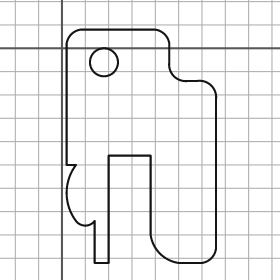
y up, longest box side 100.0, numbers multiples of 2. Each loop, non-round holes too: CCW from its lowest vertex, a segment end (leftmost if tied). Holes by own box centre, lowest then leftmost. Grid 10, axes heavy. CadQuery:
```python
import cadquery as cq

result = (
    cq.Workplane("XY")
    .moveTo(14.0, -92.0)
    .lineTo(20.0, -92.0)
    .lineTo(20.0, -46.0)
    .lineTo(38.0, -46.0)
    .lineTo(38.0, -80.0)
    .threePointArc((42.0, -88.0), (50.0, -92.0))
    .lineTo(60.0, -92.0)
    .threePointArc((64.0, -90.0), (66.0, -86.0))
    .lineTo(66.0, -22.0)
    .threePointArc((64.0, -16.0), (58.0, -14.0))
    .lineTo(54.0, -14.0)
    .threePointArc((48.0, -12.0), (46.0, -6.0))
    .lineTo(46.0, 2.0)
    .threePointArc((44.0, 6.0), (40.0, 8.0))
    .lineTo(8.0, 8.0)
    .threePointArc((4.0, 6.0), (2.0, 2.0))
    .lineTo(2.0, -50.0)
    .lineTo(6.0, -50.0)
    .threePointArc((2.0, -62.0), (6.0, -74.0))
    .threePointArc((10.0, -76.0), (14.0, -74.0))
    .close()
    .moveTo(18.0, -6.0)
    .circle(6.0)
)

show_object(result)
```